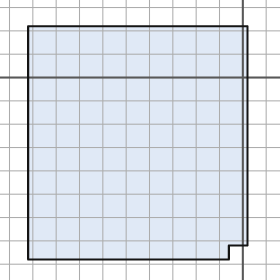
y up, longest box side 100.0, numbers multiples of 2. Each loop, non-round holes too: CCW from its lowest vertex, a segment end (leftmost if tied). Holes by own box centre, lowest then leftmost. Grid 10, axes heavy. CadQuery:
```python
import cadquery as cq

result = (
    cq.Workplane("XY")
    .moveTo(-92.0, -78.0)
    .lineTo(-6.0, -78.0)
    .lineTo(-6.0, -72.0)
    .lineTo(2.0, -72.0)
    .lineTo(2.0, 22.0)
    .lineTo(-92.0, 22.0)
    .close()
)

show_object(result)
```